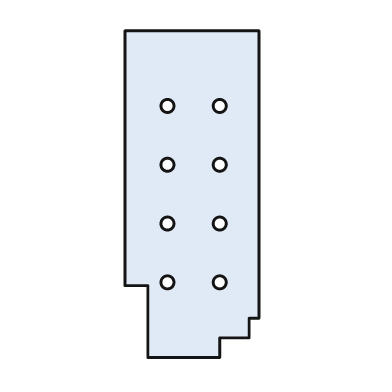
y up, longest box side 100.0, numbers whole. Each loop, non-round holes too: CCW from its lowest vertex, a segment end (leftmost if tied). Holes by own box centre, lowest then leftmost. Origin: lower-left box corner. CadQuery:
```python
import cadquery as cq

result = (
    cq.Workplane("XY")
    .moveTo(7.0, 0.0)
    .lineTo(29.0, 0.0)
    .lineTo(29.0, 6.0)
    .lineTo(38.0, 6.0)
    .lineTo(38.0, 12.0)
    .lineTo(41.0, 12.0)
    .lineTo(41.0, 100.0)
    .lineTo(0.0, 100.0)
    .lineTo(0.0, 22.0)
    .lineTo(7.0, 22.0)
    .close()
    .moveTo(13.0, 23.0)
    .circle(2.0)
    .moveTo(29.0, 23.0)
    .circle(2.0)
    .moveTo(13.0, 41.0)
    .circle(2.0)
    .moveTo(29.0, 41.0)
    .circle(2.0)
    .moveTo(13.0, 59.0)
    .circle(2.0)
    .moveTo(29.0, 59.0)
    .circle(2.0)
    .moveTo(13.0, 77.0)
    .circle(2.0)
    .moveTo(29.0, 77.0)
    .circle(2.0)
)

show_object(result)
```